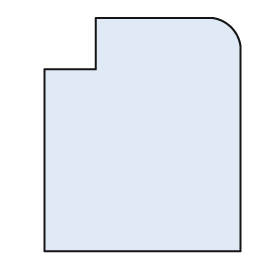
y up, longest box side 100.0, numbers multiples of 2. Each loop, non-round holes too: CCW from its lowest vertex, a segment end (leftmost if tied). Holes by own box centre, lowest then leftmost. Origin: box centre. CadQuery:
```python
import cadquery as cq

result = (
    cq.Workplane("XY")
    .moveTo(-42.0, -50.0)
    .lineTo(42.0, -50.0)
    .lineTo(42.0, 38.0)
    .threePointArc((38.0, 46.0), (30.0, 50.0))
    .lineTo(-20.0, 50.0)
    .lineTo(-20.0, 28.0)
    .lineTo(-42.0, 28.0)
    .close()
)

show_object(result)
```